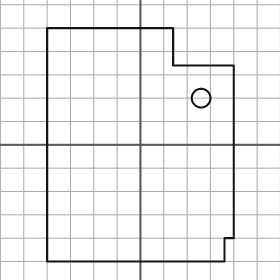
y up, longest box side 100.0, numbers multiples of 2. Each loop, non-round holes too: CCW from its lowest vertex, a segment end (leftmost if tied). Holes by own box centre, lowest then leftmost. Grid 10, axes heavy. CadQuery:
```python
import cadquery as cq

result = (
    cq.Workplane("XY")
    .moveTo(-40.0, -50.0)
    .lineTo(36.0, -50.0)
    .lineTo(36.0, -40.0)
    .lineTo(40.0, -40.0)
    .lineTo(40.0, 34.0)
    .lineTo(14.0, 34.0)
    .lineTo(14.0, 50.0)
    .lineTo(-40.0, 50.0)
    .close()
    .moveTo(26.0, 20.0)
    .circle(4.0)
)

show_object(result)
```